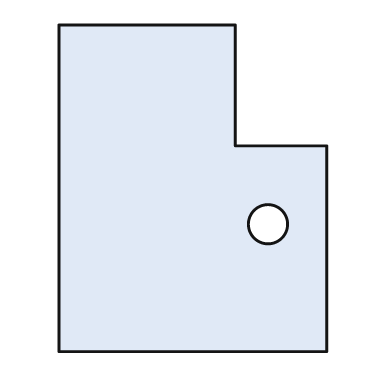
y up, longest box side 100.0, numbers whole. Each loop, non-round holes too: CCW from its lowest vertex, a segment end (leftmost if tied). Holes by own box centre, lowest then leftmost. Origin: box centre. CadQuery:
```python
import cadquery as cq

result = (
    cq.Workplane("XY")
    .moveTo(-41.0, -50.0)
    .lineTo(41.0, -50.0)
    .lineTo(41.0, 13.0)
    .lineTo(13.0, 13.0)
    .lineTo(13.0, 50.0)
    .lineTo(-41.0, 50.0)
    .close()
    .moveTo(23.0, -11.0)
    .circle(6.0)
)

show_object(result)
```